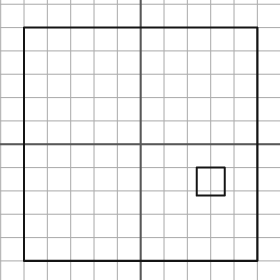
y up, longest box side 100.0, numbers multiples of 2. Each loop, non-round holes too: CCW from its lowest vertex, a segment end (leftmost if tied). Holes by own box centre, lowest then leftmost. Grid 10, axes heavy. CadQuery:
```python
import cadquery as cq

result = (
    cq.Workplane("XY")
    .moveTo(-50.0, -50.0)
    .lineTo(50.0, -50.0)
    .lineTo(50.0, 50.0)
    .lineTo(-50.0, 50.0)
    .close()
    .moveTo(24.0, -22.0)
    .lineTo(36.0, -22.0)
    .lineTo(36.0, -10.0)
    .lineTo(24.0, -10.0)
    .close()
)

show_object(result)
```